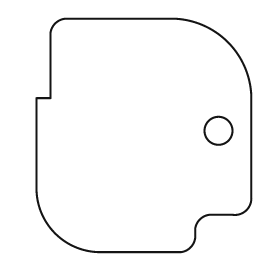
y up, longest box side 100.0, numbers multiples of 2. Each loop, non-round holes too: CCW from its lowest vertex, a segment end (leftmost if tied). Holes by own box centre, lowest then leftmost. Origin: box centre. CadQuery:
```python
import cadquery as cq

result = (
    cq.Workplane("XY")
    .moveTo(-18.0, -50.0)
    .lineTo(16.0, -50.0)
    .threePointArc((20.0, -48.0), (22.0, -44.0))
    .lineTo(22.0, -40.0)
    .threePointArc((24.0, -36.0), (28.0, -34.0))
    .lineTo(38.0, -34.0)
    .threePointArc((44.0, -32.0), (46.0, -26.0))
    .lineTo(46.0, 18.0)
    .threePointArc((36.0, 40.0), (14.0, 50.0))
    .lineTo(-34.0, 50.0)
    .threePointArc((-38.0, 48.0), (-40.0, 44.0))
    .lineTo(-40.0, 16.0)
    .lineTo(-46.0, 16.0)
    .lineTo(-46.0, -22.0)
    .threePointArc((-38.0, -42.0), (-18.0, -50.0))
    .close()
    .moveTo(32.0, 2.0)
    .circle(6.0)
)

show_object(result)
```